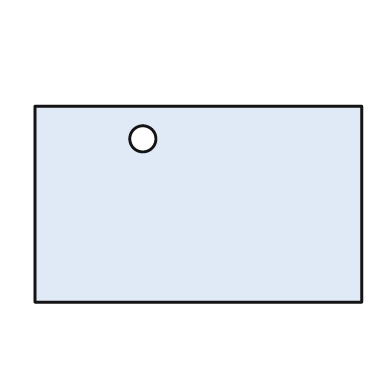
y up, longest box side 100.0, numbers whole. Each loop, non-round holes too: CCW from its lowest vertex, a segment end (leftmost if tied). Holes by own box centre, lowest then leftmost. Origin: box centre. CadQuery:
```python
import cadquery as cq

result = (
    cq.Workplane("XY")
    .moveTo(-50.0, -30.0)
    .lineTo(50.0, -30.0)
    .lineTo(50.0, 30.0)
    .lineTo(-50.0, 30.0)
    .close()
    .moveTo(-17.0, 20.0)
    .circle(4.0)
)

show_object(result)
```